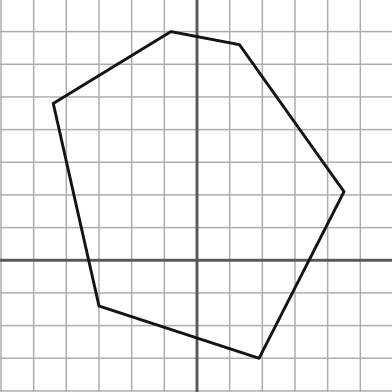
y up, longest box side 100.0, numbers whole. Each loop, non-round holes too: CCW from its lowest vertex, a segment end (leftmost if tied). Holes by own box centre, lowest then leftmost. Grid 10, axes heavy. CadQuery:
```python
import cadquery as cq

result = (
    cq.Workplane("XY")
    .moveTo(19.0, -30.0)
    .lineTo(45.0, 21.0)
    .lineTo(13.0, 66.0)
    .lineTo(-8.0, 70.0)
    .lineTo(-44.0, 48.0)
    .lineTo(-30.0, -14.0)
    .close()
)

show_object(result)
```